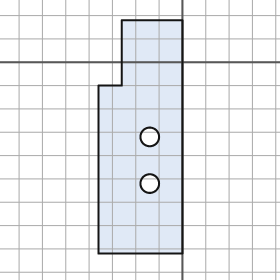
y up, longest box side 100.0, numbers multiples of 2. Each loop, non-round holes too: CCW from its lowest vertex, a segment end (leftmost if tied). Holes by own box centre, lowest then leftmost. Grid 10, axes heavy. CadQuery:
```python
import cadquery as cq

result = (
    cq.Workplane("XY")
    .moveTo(-36.0, -82.0)
    .lineTo(0.0, -82.0)
    .lineTo(0.0, 18.0)
    .lineTo(-26.0, 18.0)
    .lineTo(-26.0, -10.0)
    .lineTo(-36.0, -10.0)
    .close()
    .moveTo(-14.0, -52.0)
    .circle(4.0)
    .moveTo(-14.0, -32.0)
    .circle(4.0)
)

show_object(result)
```